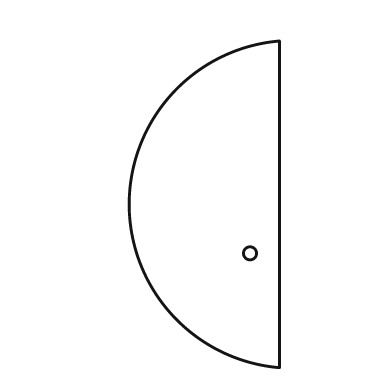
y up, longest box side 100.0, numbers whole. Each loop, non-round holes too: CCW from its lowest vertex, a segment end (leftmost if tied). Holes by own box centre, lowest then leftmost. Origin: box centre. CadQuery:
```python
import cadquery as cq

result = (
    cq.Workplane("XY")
    .moveTo(23.0, -50.0)
    .lineTo(23.0, 50.0)
    .threePointArc((-23.0, 0.0), (23.0, -50.0))
    .close()
    .moveTo(14.0, -15.0)
    .circle(2.0)
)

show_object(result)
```